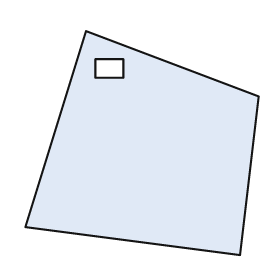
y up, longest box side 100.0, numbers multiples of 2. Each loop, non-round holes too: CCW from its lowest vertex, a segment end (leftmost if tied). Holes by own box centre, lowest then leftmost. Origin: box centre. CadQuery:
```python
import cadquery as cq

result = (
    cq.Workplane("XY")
    .moveTo(42.0, -48.0)
    .lineTo(50.0, 20.0)
    .lineTo(-24.0, 48.0)
    .lineTo(-50.0, -36.0)
    .close()
    .moveTo(-20.0, 28.0)
    .lineTo(-8.0, 28.0)
    .lineTo(-8.0, 36.0)
    .lineTo(-20.0, 36.0)
    .close()
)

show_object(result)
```